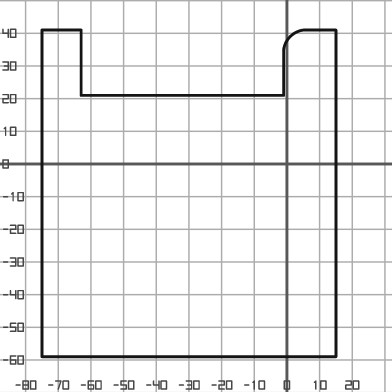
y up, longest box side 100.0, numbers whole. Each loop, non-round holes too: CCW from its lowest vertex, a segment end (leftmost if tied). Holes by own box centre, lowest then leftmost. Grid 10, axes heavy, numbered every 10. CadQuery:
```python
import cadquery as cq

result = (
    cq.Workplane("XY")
    .moveTo(-75.0, -59.0)
    .lineTo(15.0, -59.0)
    .lineTo(15.0, 41.0)
    .lineTo(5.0, 41.0)
    .threePointArc((1.0, 39.0), (-1.0, 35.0))
    .lineTo(-1.0, 21.0)
    .lineTo(-63.0, 21.0)
    .lineTo(-63.0, 41.0)
    .lineTo(-75.0, 41.0)
    .close()
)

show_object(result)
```